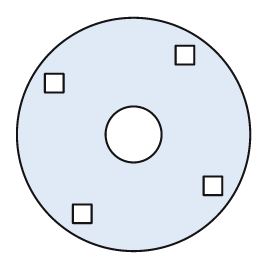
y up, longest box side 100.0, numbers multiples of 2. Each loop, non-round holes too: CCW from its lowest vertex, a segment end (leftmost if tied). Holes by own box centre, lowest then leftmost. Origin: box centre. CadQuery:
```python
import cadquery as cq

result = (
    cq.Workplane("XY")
    .moveTo(0.0, 0.0)
    .circle(50.0)
    .moveTo(-26.0, -38.0)
    .lineTo(-18.0, -38.0)
    .lineTo(-18.0, -30.0)
    .lineTo(-26.0, -30.0)
    .close()
    .moveTo(30.0, -26.0)
    .lineTo(38.0, -26.0)
    .lineTo(38.0, -18.0)
    .lineTo(30.0, -18.0)
    .close()
    .moveTo(0.0, 0.0)
    .circle(12.0)
    .moveTo(-38.0, 18.0)
    .lineTo(-30.0, 18.0)
    .lineTo(-30.0, 26.0)
    .lineTo(-38.0, 26.0)
    .close()
    .moveTo(18.0, 30.0)
    .lineTo(26.0, 30.0)
    .lineTo(26.0, 38.0)
    .lineTo(18.0, 38.0)
    .close()
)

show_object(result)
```